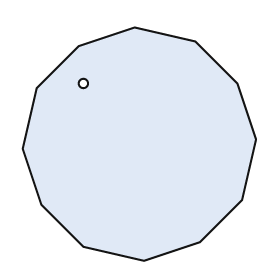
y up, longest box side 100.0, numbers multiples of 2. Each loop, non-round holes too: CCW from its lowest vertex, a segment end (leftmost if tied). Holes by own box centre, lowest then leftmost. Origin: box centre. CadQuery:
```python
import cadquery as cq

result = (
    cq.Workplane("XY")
    .moveTo(2.0, -50.0)
    .lineTo(26.0, -42.0)
    .lineTo(44.0, -24.0)
    .lineTo(50.0, 2.0)
    .lineTo(42.0, 26.0)
    .lineTo(24.0, 44.0)
    .lineTo(-2.0, 50.0)
    .lineTo(-26.0, 42.0)
    .lineTo(-44.0, 24.0)
    .lineTo(-50.0, -2.0)
    .lineTo(-42.0, -26.0)
    .lineTo(-24.0, -44.0)
    .close()
    .moveTo(-24.0, 26.0)
    .circle(2.0)
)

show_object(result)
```